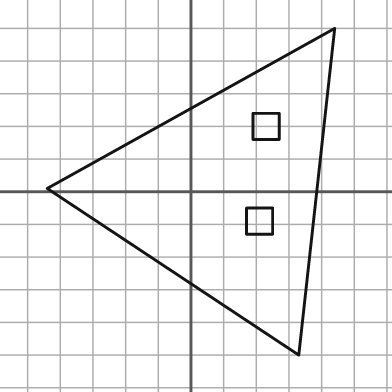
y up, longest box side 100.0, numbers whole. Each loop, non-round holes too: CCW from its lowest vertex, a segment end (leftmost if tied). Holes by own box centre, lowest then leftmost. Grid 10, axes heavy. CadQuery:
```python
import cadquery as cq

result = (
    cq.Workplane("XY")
    .moveTo(33.0, -50.0)
    .lineTo(44.0, 50.0)
    .lineTo(-44.0, 1.0)
    .close()
    .moveTo(17.0, -13.0)
    .lineTo(25.0, -13.0)
    .lineTo(25.0, -5.0)
    .lineTo(17.0, -5.0)
    .close()
    .moveTo(19.0, 16.0)
    .lineTo(27.0, 16.0)
    .lineTo(27.0, 24.0)
    .lineTo(19.0, 24.0)
    .close()
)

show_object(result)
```